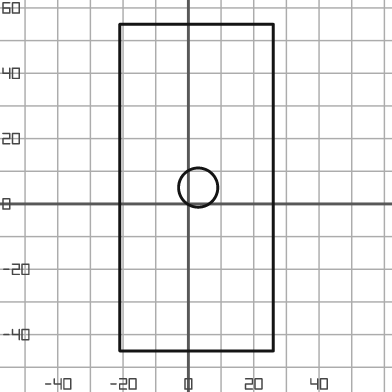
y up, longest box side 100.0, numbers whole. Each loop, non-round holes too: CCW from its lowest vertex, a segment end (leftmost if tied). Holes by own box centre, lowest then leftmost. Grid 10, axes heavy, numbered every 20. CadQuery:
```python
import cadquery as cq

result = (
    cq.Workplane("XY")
    .moveTo(-21.0, -45.0)
    .lineTo(26.0, -45.0)
    .lineTo(26.0, 55.0)
    .lineTo(-21.0, 55.0)
    .close()
    .moveTo(3.0, 5.0)
    .circle(6.0)
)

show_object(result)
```